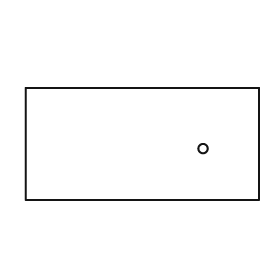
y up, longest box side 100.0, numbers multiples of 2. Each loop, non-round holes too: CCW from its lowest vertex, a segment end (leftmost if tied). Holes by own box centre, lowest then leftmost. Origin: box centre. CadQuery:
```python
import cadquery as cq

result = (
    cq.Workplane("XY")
    .moveTo(-50.0, -24.0)
    .lineTo(50.0, -24.0)
    .lineTo(50.0, 24.0)
    .lineTo(-50.0, 24.0)
    .close()
    .moveTo(26.0, -2.0)
    .circle(2.0)
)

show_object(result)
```